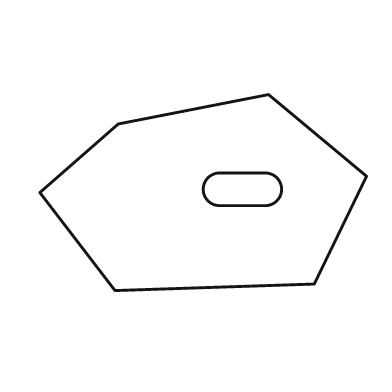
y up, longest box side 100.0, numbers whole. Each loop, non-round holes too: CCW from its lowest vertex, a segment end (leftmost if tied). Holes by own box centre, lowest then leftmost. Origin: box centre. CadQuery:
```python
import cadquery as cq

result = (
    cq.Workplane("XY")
    .moveTo(-27.0, -30.0)
    .lineTo(34.0, -28.0)
    .lineTo(50.0, 5.0)
    .lineTo(20.0, 30.0)
    .lineTo(-26.0, 21.0)
    .lineTo(-50.0, 0.0)
    .close()
    .moveTo(5.0, -4.0)
    .lineTo(19.0, -4.0)
    .threePointArc((24.0, 1.0), (19.0, 6.0))
    .lineTo(5.0, 6.0)
    .threePointArc((0.0, 1.0), (5.0, -4.0))
    .close()
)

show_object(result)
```